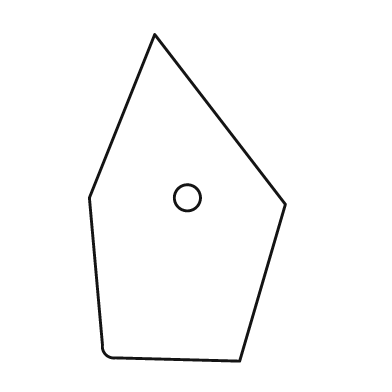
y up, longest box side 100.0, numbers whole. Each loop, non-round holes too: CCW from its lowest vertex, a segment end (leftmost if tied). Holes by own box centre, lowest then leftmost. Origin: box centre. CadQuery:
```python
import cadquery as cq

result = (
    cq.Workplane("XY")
    .moveTo(16.0, -50.0)
    .lineTo(30.0, -2.0)
    .lineTo(-10.0, 50.0)
    .lineTo(-30.0, 0.0)
    .lineTo(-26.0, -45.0)
    .threePointArc((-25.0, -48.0), (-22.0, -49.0))
    .close()
    .moveTo(0.0, 0.0)
    .circle(4.0)
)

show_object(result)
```